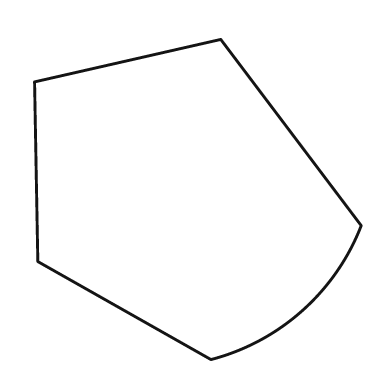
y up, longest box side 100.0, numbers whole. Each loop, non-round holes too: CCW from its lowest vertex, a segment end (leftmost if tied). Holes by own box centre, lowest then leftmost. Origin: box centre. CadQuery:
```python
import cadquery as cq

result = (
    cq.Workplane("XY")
    .moveTo(4.0, -49.0)
    .threePointArc((32.0, -34.0), (50.0, -8.0))
    .lineTo(7.0, 49.0)
    .lineTo(-50.0, 36.0)
    .lineTo(-49.0, -19.0)
    .close()
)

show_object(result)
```